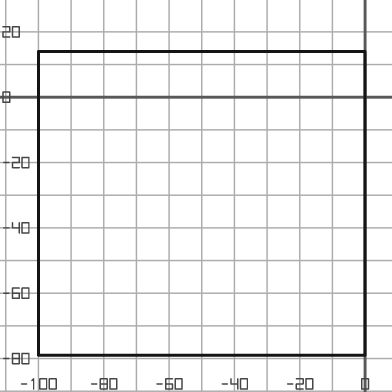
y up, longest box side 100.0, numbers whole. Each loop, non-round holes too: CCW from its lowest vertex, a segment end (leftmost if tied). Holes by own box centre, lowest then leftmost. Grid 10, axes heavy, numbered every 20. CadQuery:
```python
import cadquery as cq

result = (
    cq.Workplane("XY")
    .moveTo(-100.0, -79.0)
    .lineTo(0.0, -79.0)
    .lineTo(0.0, 14.0)
    .lineTo(-100.0, 14.0)
    .close()
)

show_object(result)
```